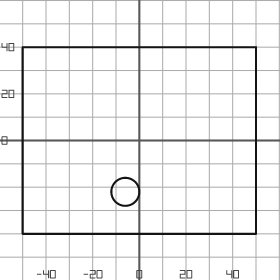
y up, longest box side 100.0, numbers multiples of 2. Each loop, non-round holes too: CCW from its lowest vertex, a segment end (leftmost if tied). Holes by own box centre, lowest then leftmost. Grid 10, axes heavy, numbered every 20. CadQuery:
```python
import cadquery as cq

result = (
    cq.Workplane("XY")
    .moveTo(-50.0, -40.0)
    .lineTo(50.0, -40.0)
    .lineTo(50.0, 40.0)
    .lineTo(-50.0, 40.0)
    .close()
    .moveTo(-6.0, -22.0)
    .circle(6.0)
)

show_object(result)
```